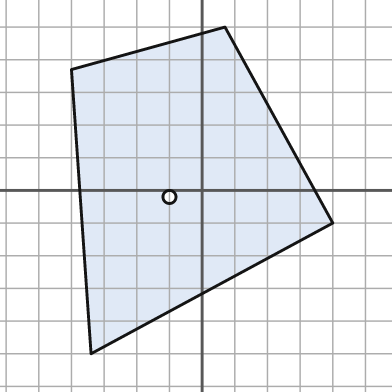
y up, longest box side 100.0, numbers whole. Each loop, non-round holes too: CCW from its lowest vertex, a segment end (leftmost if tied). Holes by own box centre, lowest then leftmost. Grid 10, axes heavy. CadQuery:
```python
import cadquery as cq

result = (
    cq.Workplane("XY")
    .moveTo(-34.0, -50.0)
    .lineTo(40.0, -10.0)
    .lineTo(7.0, 50.0)
    .lineTo(-40.0, 37.0)
    .close()
    .moveTo(-10.0, -2.0)
    .circle(2.0)
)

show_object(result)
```